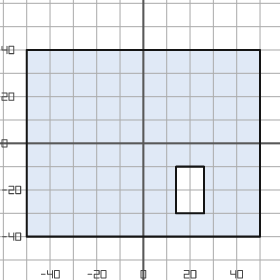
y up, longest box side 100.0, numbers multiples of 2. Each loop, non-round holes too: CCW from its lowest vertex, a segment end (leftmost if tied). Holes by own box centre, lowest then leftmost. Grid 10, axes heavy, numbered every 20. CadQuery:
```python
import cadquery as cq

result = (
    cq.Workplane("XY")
    .moveTo(-50.0, -40.0)
    .lineTo(50.0, -40.0)
    .lineTo(50.0, 40.0)
    .lineTo(-50.0, 40.0)
    .close()
    .moveTo(14.0, -30.0)
    .lineTo(26.0, -30.0)
    .lineTo(26.0, -10.0)
    .lineTo(14.0, -10.0)
    .close()
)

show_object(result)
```